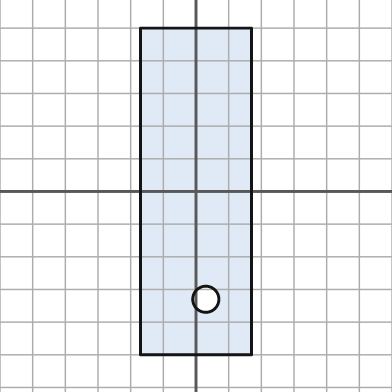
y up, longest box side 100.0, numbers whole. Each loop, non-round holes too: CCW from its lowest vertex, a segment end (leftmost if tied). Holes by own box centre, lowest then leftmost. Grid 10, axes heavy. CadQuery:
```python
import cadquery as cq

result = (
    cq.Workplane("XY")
    .moveTo(-17.0, -50.0)
    .lineTo(17.0, -50.0)
    .lineTo(17.0, 50.0)
    .lineTo(-17.0, 50.0)
    .close()
    .moveTo(3.0, -33.0)
    .circle(4.0)
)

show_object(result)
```